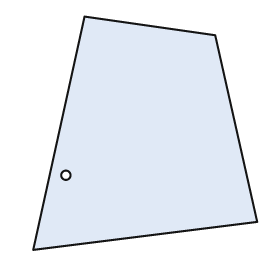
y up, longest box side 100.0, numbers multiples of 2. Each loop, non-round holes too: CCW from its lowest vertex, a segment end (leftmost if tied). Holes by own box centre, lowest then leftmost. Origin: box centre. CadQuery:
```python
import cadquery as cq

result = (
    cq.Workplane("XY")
    .moveTo(-48.0, -50.0)
    .lineTo(48.0, -38.0)
    .lineTo(30.0, 42.0)
    .lineTo(-26.0, 50.0)
    .close()
    .moveTo(-34.0, -18.0)
    .circle(2.0)
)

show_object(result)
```